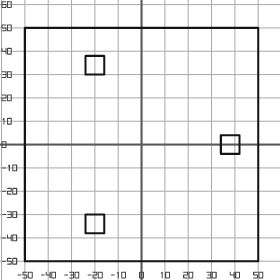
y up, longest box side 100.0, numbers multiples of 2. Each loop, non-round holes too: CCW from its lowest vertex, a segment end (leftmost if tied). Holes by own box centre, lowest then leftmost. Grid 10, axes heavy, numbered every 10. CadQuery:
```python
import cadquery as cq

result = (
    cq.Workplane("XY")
    .moveTo(-50.0, -50.0)
    .lineTo(50.0, -50.0)
    .lineTo(50.0, 50.0)
    .lineTo(-50.0, 50.0)
    .close()
    .moveTo(-24.0, -38.0)
    .lineTo(-16.0, -38.0)
    .lineTo(-16.0, -30.0)
    .lineTo(-24.0, -30.0)
    .close()
    .moveTo(34.0, -4.0)
    .lineTo(42.0, -4.0)
    .lineTo(42.0, 4.0)
    .lineTo(34.0, 4.0)
    .close()
    .moveTo(-24.0, 30.0)
    .lineTo(-16.0, 30.0)
    .lineTo(-16.0, 38.0)
    .lineTo(-24.0, 38.0)
    .close()
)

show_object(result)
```